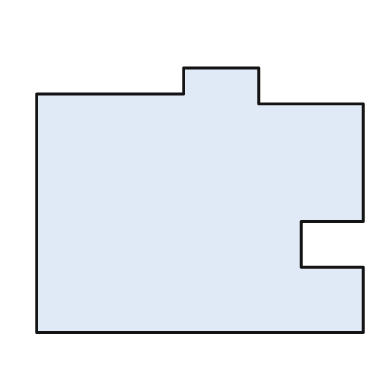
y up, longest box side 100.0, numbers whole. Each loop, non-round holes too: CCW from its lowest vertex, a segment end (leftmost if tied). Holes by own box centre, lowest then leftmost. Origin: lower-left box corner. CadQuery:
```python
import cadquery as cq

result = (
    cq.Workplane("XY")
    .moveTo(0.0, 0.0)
    .lineTo(100.0, 0.0)
    .lineTo(100.0, 20.0)
    .lineTo(81.0, 20.0)
    .lineTo(81.0, 34.0)
    .lineTo(100.0, 34.0)
    .lineTo(100.0, 70.0)
    .lineTo(68.0, 70.0)
    .lineTo(68.0, 81.0)
    .lineTo(45.0, 81.0)
    .lineTo(45.0, 73.0)
    .lineTo(0.0, 73.0)
    .close()
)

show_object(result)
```